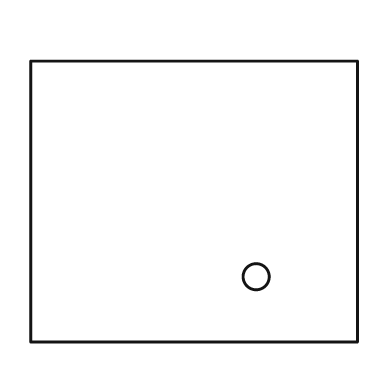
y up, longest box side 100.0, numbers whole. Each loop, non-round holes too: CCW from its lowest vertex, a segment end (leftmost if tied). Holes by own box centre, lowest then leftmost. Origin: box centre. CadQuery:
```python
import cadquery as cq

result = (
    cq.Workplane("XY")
    .moveTo(-50.0, -43.0)
    .lineTo(50.0, -43.0)
    .lineTo(50.0, 43.0)
    .lineTo(-50.0, 43.0)
    .close()
    .moveTo(19.0, -23.0)
    .circle(4.0)
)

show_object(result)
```